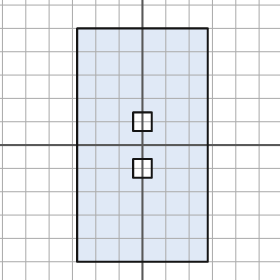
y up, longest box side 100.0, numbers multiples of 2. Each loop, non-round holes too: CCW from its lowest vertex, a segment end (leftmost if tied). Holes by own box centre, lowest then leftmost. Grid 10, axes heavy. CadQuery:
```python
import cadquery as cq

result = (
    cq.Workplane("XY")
    .moveTo(-28.0, -50.0)
    .lineTo(28.0, -50.0)
    .lineTo(28.0, 50.0)
    .lineTo(-28.0, 50.0)
    .close()
    .moveTo(-4.0, -14.0)
    .lineTo(4.0, -14.0)
    .lineTo(4.0, -6.0)
    .lineTo(-4.0, -6.0)
    .close()
    .moveTo(-4.0, 6.0)
    .lineTo(4.0, 6.0)
    .lineTo(4.0, 14.0)
    .lineTo(-4.0, 14.0)
    .close()
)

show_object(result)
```